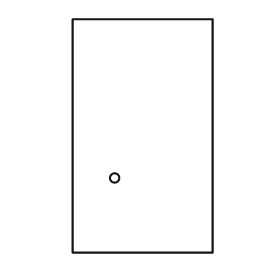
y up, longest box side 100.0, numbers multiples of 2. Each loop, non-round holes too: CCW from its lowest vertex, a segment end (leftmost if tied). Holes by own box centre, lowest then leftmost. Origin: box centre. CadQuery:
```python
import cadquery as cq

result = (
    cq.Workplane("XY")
    .moveTo(-30.0, -50.0)
    .lineTo(30.0, -50.0)
    .lineTo(30.0, 50.0)
    .lineTo(-30.0, 50.0)
    .close()
    .moveTo(-12.0, -18.0)
    .circle(2.0)
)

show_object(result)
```